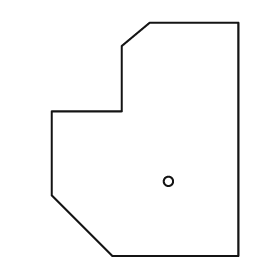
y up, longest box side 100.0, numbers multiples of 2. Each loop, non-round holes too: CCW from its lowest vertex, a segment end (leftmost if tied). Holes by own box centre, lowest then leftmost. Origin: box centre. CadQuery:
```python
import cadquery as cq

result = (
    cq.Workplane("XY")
    .moveTo(-14.0, -50.0)
    .lineTo(40.0, -50.0)
    .lineTo(40.0, 50.0)
    .lineTo(2.0, 50.0)
    .lineTo(-10.0, 40.0)
    .lineTo(-10.0, 12.0)
    .lineTo(-40.0, 12.0)
    .lineTo(-40.0, -24.0)
    .close()
    .moveTo(10.0, -18.0)
    .circle(2.0)
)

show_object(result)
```